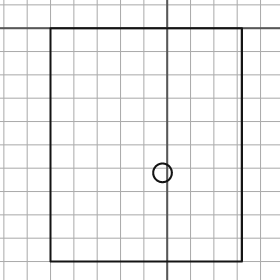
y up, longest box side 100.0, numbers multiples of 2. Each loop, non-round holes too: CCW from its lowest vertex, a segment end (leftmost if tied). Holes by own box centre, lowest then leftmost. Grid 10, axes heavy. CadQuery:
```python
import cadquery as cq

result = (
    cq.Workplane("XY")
    .moveTo(-50.0, -100.0)
    .lineTo(32.0, -100.0)
    .lineTo(32.0, 0.0)
    .lineTo(-50.0, 0.0)
    .close()
    .moveTo(-2.0, -62.0)
    .circle(4.0)
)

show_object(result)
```